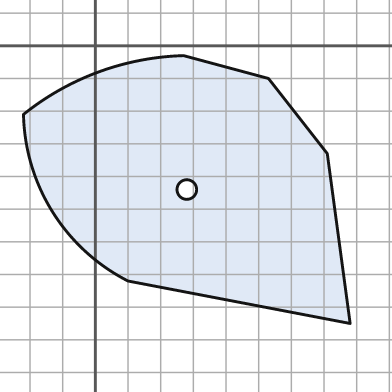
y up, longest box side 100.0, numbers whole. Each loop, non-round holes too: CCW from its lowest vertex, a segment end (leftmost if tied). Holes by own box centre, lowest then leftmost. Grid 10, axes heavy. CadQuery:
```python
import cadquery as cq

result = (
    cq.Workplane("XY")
    .moveTo(78.0, -85.0)
    .lineTo(71.0, -33.0)
    .lineTo(53.0, -10.0)
    .lineTo(27.0, -3.0)
    .threePointArc((1.0, -8.0), (-22.0, -21.0))
    .threePointArc((-13.0, -51.0), (10.0, -72.0))
    .close()
    .moveTo(28.0, -44.0)
    .circle(3.0)
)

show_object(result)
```